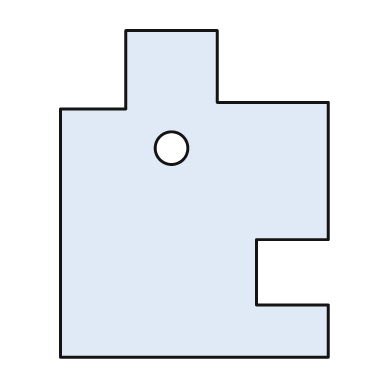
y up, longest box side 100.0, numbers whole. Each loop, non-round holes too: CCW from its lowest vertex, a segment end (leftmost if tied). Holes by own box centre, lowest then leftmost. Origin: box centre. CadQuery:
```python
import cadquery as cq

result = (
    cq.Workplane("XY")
    .moveTo(-41.0, -50.0)
    .lineTo(41.0, -50.0)
    .lineTo(41.0, -34.0)
    .lineTo(19.0, -34.0)
    .lineTo(19.0, -14.0)
    .lineTo(41.0, -14.0)
    .lineTo(41.0, 28.0)
    .lineTo(7.0, 28.0)
    .lineTo(7.0, 50.0)
    .lineTo(-21.0, 50.0)
    .lineTo(-21.0, 26.0)
    .lineTo(-41.0, 26.0)
    .close()
    .moveTo(-7.0, 14.0)
    .circle(5.0)
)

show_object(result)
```